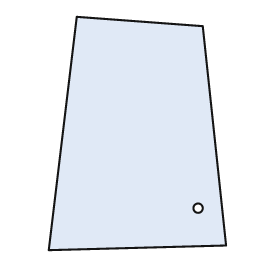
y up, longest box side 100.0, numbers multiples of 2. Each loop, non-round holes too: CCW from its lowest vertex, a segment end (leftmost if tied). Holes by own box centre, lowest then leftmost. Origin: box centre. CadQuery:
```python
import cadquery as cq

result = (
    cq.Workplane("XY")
    .moveTo(-38.0, -50.0)
    .lineTo(38.0, -48.0)
    .lineTo(28.0, 46.0)
    .lineTo(-26.0, 50.0)
    .close()
    .moveTo(26.0, -32.0)
    .circle(2.0)
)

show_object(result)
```